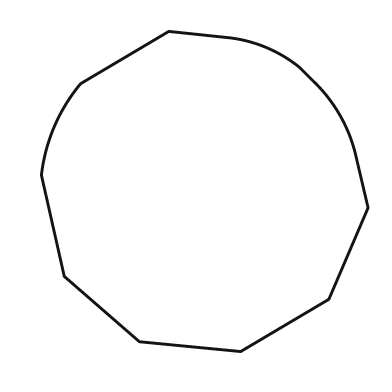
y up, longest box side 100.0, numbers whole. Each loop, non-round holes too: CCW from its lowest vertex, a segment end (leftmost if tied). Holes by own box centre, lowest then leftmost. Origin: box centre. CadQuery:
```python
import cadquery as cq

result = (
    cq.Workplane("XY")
    .moveTo(11.0, -49.0)
    .lineTo(38.0, -33.0)
    .lineTo(50.0, -5.0)
    .lineTo(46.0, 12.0)
    .threePointArc((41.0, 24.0), (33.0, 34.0))
    .lineTo(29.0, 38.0)
    .threePointArc((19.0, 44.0), (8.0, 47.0))
    .lineTo(-11.0, 49.0)
    .lineTo(-38.0, 33.0)
    .threePointArc((-46.0, 20.0), (-50.0, 5.0))
    .lineTo(-43.0, -26.0)
    .lineTo(-20.0, -46.0)
    .close()
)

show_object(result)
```